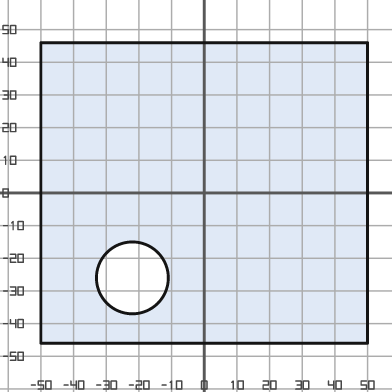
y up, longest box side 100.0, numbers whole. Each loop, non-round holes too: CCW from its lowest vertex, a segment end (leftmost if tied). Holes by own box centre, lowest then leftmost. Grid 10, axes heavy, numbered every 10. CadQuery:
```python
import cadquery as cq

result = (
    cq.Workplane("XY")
    .moveTo(-50.0, -46.0)
    .lineTo(50.0, -46.0)
    .lineTo(50.0, 46.0)
    .lineTo(-50.0, 46.0)
    .close()
    .moveTo(-22.0, -26.0)
    .circle(11.0)
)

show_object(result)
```